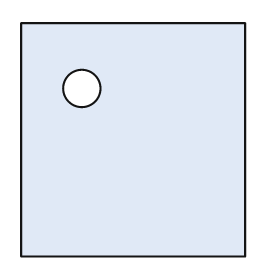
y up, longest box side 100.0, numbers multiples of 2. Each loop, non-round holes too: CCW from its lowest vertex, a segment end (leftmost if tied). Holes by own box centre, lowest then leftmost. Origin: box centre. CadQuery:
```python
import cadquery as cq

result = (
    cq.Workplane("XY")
    .moveTo(-48.0, -50.0)
    .lineTo(48.0, -50.0)
    .lineTo(48.0, 50.0)
    .lineTo(-48.0, 50.0)
    .close()
    .moveTo(-22.0, 22.0)
    .circle(8.0)
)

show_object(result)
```